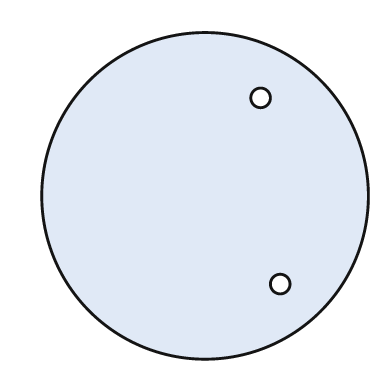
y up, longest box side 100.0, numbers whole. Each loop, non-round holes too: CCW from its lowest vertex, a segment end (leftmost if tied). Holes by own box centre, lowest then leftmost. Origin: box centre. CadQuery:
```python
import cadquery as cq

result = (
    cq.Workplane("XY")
    .moveTo(0.0, 0.0)
    .circle(50.0)
    .moveTo(23.0, -27.0)
    .circle(3.0)
    .moveTo(17.0, 30.0)
    .circle(3.0)
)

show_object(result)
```